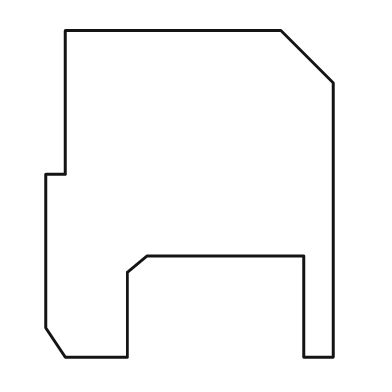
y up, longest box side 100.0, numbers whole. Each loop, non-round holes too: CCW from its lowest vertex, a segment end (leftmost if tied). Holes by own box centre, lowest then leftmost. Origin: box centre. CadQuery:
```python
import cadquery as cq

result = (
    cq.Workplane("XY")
    .moveTo(-38.0, -50.0)
    .lineTo(-19.0, -50.0)
    .lineTo(-19.0, -24.0)
    .lineTo(-13.0, -19.0)
    .lineTo(35.0, -19.0)
    .lineTo(35.0, -50.0)
    .lineTo(44.0, -50.0)
    .lineTo(44.0, 34.0)
    .lineTo(28.0, 50.0)
    .lineTo(-38.0, 50.0)
    .lineTo(-38.0, 6.0)
    .lineTo(-44.0, 6.0)
    .lineTo(-44.0, -41.0)
    .close()
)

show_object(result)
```